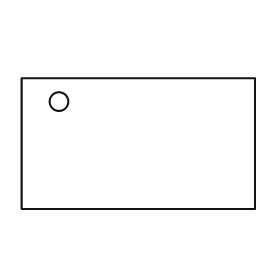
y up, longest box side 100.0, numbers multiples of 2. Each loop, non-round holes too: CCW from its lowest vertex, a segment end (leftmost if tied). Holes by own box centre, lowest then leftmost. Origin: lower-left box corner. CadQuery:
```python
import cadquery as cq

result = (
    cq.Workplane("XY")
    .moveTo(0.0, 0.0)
    .lineTo(100.0, 0.0)
    .lineTo(100.0, 56.0)
    .lineTo(0.0, 56.0)
    .close()
    .moveTo(16.0, 46.0)
    .circle(4.0)
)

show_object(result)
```